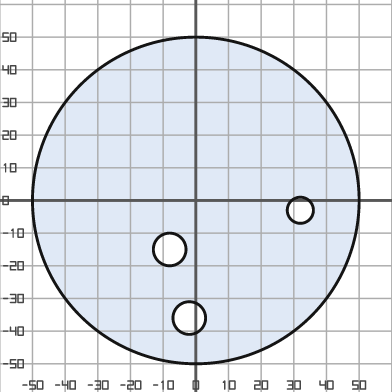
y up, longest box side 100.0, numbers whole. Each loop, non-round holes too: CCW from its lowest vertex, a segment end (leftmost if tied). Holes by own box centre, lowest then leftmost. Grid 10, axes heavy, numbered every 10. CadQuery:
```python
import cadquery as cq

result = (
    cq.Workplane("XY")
    .moveTo(0.0, 0.0)
    .circle(50.0)
    .moveTo(-2.0, -36.0)
    .circle(5.0)
    .moveTo(-8.0, -15.0)
    .circle(5.0)
    .moveTo(32.0, -3.0)
    .circle(4.0)
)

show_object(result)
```